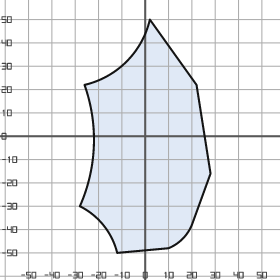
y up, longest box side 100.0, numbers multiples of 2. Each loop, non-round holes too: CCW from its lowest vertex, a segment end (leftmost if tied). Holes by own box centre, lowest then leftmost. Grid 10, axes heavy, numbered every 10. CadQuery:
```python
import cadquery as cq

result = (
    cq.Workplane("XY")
    .moveTo(-12.0, -50.0)
    .lineTo(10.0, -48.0)
    .threePointArc((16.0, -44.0), (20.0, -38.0))
    .lineTo(28.0, -16.0)
    .lineTo(22.0, 22.0)
    .lineTo(2.0, 50.0)
    .threePointArc((-8.0, 32.0), (-26.0, 22.0))
    .threePointArc((-22.0, -4.0), (-28.0, -30.0))
    .threePointArc((-18.0, -38.0), (-12.0, -50.0))
    .close()
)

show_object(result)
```